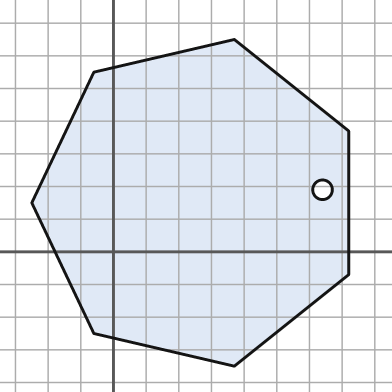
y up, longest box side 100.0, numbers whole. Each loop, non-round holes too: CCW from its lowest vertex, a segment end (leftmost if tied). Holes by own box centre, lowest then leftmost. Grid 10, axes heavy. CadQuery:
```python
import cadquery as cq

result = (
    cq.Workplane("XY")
    .moveTo(37.0, -35.0)
    .lineTo(72.0, -7.0)
    .lineTo(72.0, 37.0)
    .lineTo(37.0, 65.0)
    .lineTo(-6.0, 55.0)
    .lineTo(-25.0, 15.0)
    .lineTo(-6.0, -25.0)
    .close()
    .moveTo(64.0, 19.0)
    .circle(3.0)
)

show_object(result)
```